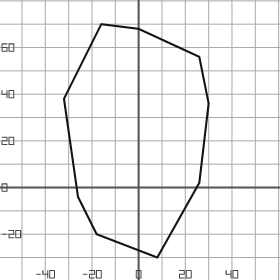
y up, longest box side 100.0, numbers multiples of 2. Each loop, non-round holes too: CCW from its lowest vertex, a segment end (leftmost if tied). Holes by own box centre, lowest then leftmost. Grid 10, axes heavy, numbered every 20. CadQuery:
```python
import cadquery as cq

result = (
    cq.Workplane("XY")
    .moveTo(8.0, -30.0)
    .lineTo(26.0, 2.0)
    .lineTo(30.0, 36.0)
    .lineTo(26.0, 56.0)
    .lineTo(0.0, 68.0)
    .lineTo(-16.0, 70.0)
    .lineTo(-32.0, 38.0)
    .lineTo(-26.0, -4.0)
    .lineTo(-18.0, -20.0)
    .close()
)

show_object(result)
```